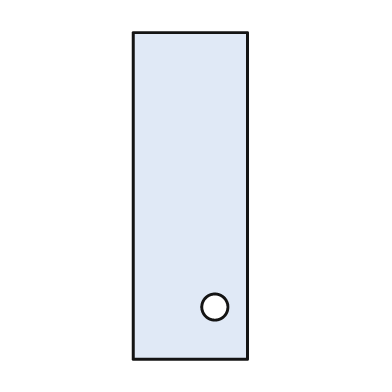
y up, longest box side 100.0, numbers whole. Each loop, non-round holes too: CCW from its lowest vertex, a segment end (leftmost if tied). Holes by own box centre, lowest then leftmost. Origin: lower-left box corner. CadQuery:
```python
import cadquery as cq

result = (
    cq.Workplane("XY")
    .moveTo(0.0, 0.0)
    .lineTo(35.0, 0.0)
    .lineTo(35.0, 100.0)
    .lineTo(0.0, 100.0)
    .close()
    .moveTo(25.0, 16.0)
    .circle(4.0)
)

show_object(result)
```